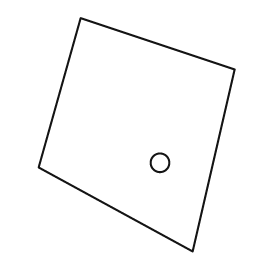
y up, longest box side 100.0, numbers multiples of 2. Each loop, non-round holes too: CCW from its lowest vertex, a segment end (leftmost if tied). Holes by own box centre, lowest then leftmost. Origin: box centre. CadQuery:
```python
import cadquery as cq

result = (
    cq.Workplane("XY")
    .moveTo(24.0, -50.0)
    .lineTo(42.0, 28.0)
    .lineTo(-24.0, 50.0)
    .lineTo(-42.0, -14.0)
    .close()
    .moveTo(10.0, -12.0)
    .circle(4.0)
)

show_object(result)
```